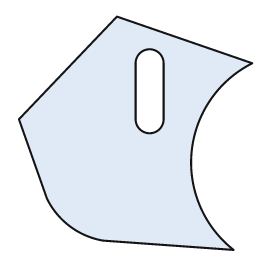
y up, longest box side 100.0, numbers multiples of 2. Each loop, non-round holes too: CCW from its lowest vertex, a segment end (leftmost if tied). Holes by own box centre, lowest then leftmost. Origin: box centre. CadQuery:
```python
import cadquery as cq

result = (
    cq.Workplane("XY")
    .moveTo(42.0, -50.0)
    .threePointArc((24.0, -8.0), (50.0, 30.0))
    .lineTo(-8.0, 50.0)
    .lineTo(-50.0, 6.0)
    .lineTo(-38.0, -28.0)
    .threePointArc((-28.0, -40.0), (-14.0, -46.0))
    .close()
    .moveTo(0.0, 6.0)
    .threePointArc((6.0, 0.0), (12.0, 6.0))
    .lineTo(12.0, 30.0)
    .threePointArc((6.0, 36.0), (0.0, 30.0))
    .close()
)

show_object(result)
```